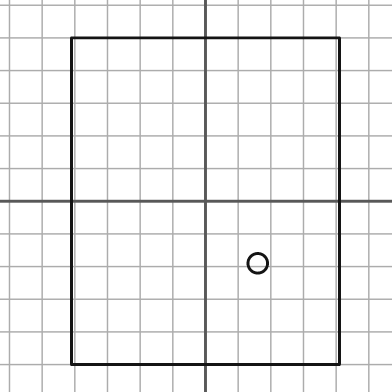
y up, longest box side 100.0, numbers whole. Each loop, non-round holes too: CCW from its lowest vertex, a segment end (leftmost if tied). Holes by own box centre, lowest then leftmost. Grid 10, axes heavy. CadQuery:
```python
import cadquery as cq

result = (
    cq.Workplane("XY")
    .moveTo(-41.0, -50.0)
    .lineTo(41.0, -50.0)
    .lineTo(41.0, 50.0)
    .lineTo(-41.0, 50.0)
    .close()
    .moveTo(16.0, -19.0)
    .circle(3.0)
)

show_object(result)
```